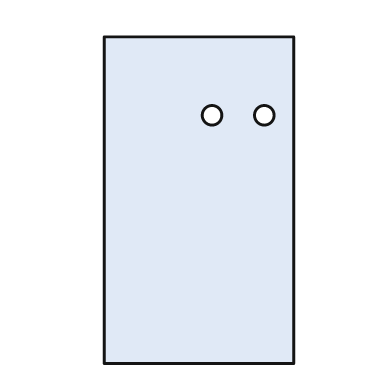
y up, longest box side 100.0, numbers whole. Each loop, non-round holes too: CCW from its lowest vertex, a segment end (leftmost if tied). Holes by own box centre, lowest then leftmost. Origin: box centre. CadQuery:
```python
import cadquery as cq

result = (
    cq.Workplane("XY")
    .moveTo(-29.0, -50.0)
    .lineTo(29.0, -50.0)
    .lineTo(29.0, 50.0)
    .lineTo(-29.0, 50.0)
    .close()
    .moveTo(4.0, 26.0)
    .circle(3.0)
    .moveTo(20.0, 26.0)
    .circle(3.0)
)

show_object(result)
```